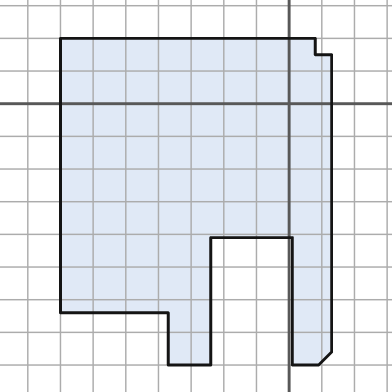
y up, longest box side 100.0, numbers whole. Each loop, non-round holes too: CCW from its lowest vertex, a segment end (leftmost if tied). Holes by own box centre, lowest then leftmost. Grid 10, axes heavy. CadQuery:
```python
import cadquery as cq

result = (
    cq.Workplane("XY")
    .moveTo(-37.0, -80.0)
    .lineTo(-24.0, -80.0)
    .lineTo(-24.0, -41.0)
    .lineTo(1.0, -41.0)
    .lineTo(1.0, -80.0)
    .lineTo(9.0, -80.0)
    .lineTo(13.0, -76.0)
    .lineTo(13.0, 15.0)
    .lineTo(8.0, 15.0)
    .lineTo(8.0, 20.0)
    .lineTo(-70.0, 20.0)
    .lineTo(-70.0, -64.0)
    .lineTo(-37.0, -64.0)
    .close()
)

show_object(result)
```